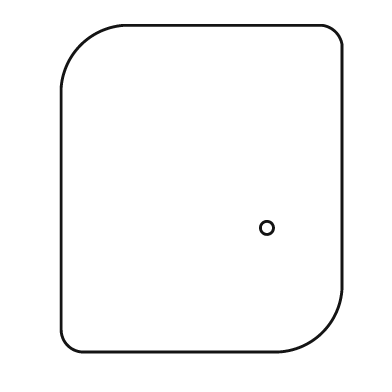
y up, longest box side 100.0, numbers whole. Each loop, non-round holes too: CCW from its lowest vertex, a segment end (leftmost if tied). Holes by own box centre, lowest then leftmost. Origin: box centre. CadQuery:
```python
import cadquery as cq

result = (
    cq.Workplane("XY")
    .moveTo(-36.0, -50.0)
    .lineTo(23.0, -50.0)
    .threePointArc((37.0, -44.0), (43.0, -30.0))
    .lineTo(43.0, 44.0)
    .threePointArc((41.0, 48.0), (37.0, 50.0))
    .lineTo(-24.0, 50.0)
    .threePointArc((-37.0, 44.0), (-43.0, 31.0))
    .lineTo(-43.0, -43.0)
    .threePointArc((-41.0, -48.0), (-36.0, -50.0))
    .close()
    .moveTo(20.0, -12.0)
    .circle(2.0)
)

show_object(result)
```